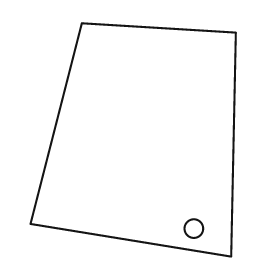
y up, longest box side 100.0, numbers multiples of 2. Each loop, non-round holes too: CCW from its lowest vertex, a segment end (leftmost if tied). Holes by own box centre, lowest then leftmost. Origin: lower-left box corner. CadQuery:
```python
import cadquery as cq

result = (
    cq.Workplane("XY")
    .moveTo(86.0, 0.0)
    .lineTo(88.0, 96.0)
    .lineTo(22.0, 100.0)
    .lineTo(0.0, 14.0)
    .close()
    .moveTo(70.0, 12.0)
    .circle(4.0)
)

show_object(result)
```